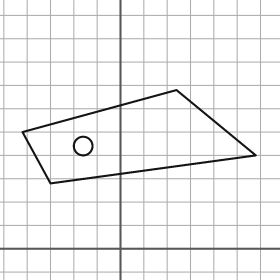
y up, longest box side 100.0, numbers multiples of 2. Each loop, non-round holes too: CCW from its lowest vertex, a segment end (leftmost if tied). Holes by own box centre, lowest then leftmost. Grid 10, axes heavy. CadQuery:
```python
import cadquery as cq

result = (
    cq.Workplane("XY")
    .moveTo(-30.0, 28.0)
    .lineTo(58.0, 40.0)
    .lineTo(24.0, 68.0)
    .lineTo(-42.0, 50.0)
    .close()
    .moveTo(-16.0, 44.0)
    .circle(4.0)
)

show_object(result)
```